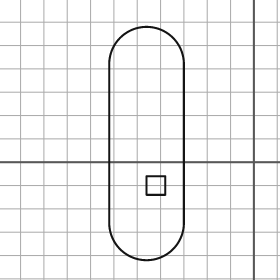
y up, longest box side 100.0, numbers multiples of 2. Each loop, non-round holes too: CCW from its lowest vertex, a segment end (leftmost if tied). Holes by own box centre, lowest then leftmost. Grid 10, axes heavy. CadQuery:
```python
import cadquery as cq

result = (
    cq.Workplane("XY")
    .moveTo(-62.0, -26.0)
    .threePointArc((-46.0, -42.0), (-30.0, -26.0))
    .lineTo(-30.0, 42.0)
    .threePointArc((-46.0, 58.0), (-62.0, 42.0))
    .close()
    .moveTo(-46.0, -14.0)
    .lineTo(-38.0, -14.0)
    .lineTo(-38.0, -6.0)
    .lineTo(-46.0, -6.0)
    .close()
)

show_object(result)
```